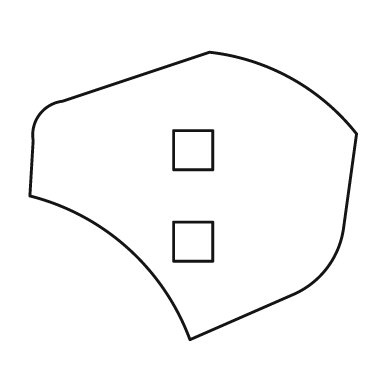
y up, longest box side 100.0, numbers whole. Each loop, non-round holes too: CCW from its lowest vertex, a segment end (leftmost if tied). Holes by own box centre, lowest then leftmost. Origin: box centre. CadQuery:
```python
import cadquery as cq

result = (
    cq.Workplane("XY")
    .moveTo(-1.0, -44.0)
    .lineTo(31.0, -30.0)
    .threePointArc((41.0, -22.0), (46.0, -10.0))
    .lineTo(50.0, 19.0)
    .threePointArc((30.0, 36.0), (5.0, 44.0))
    .lineTo(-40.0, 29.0)
    .threePointArc((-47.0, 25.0), (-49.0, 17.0))
    .lineTo(-50.0, 0.0)
    .threePointArc((-20.0, -16.0), (-1.0, -44.0))
    .close()
    .moveTo(-6.0, -20.0)
    .lineTo(6.0, -20.0)
    .lineTo(6.0, -8.0)
    .lineTo(-6.0, -8.0)
    .close()
    .moveTo(-6.0, 8.0)
    .lineTo(6.0, 8.0)
    .lineTo(6.0, 20.0)
    .lineTo(-6.0, 20.0)
    .close()
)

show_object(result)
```